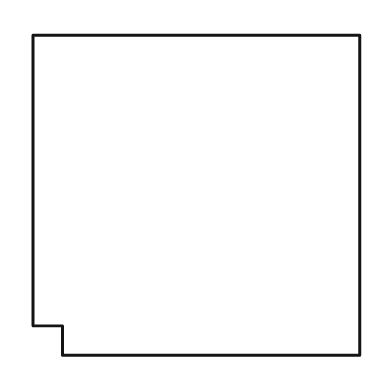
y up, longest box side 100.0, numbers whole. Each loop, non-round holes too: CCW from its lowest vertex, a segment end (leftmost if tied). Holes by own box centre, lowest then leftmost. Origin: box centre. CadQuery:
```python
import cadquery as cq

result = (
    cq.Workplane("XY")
    .moveTo(-41.0, -49.0)
    .lineTo(50.0, -49.0)
    .lineTo(50.0, 49.0)
    .lineTo(-50.0, 49.0)
    .lineTo(-50.0, -40.0)
    .lineTo(-41.0, -40.0)
    .close()
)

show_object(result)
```